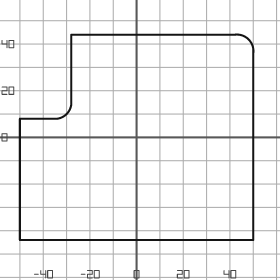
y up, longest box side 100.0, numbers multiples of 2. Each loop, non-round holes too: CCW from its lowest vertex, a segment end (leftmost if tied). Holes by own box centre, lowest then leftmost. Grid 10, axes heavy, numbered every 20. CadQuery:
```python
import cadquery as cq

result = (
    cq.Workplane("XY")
    .moveTo(-50.0, -44.0)
    .lineTo(50.0, -44.0)
    .lineTo(50.0, 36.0)
    .threePointArc((48.0, 42.0), (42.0, 44.0))
    .lineTo(-28.0, 44.0)
    .lineTo(-28.0, 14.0)
    .threePointArc((-30.0, 10.0), (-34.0, 8.0))
    .lineTo(-50.0, 8.0)
    .close()
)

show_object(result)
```